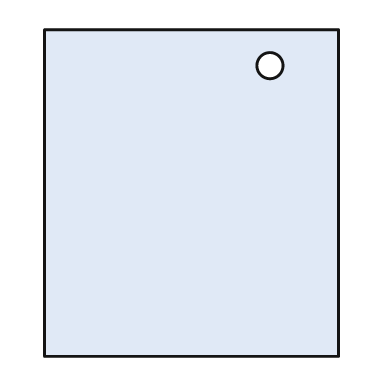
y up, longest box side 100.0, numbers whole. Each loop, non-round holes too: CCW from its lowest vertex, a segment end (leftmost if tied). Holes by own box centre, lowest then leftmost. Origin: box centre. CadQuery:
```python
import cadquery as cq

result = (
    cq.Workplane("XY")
    .moveTo(-45.0, -50.0)
    .lineTo(45.0, -50.0)
    .lineTo(45.0, 50.0)
    .lineTo(-45.0, 50.0)
    .close()
    .moveTo(24.0, 39.0)
    .circle(4.0)
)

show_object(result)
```